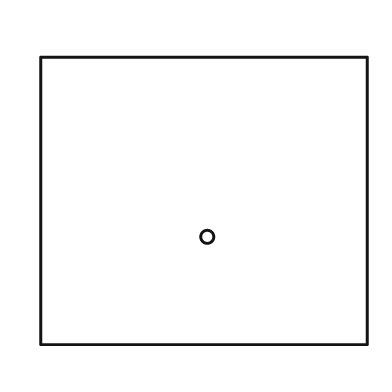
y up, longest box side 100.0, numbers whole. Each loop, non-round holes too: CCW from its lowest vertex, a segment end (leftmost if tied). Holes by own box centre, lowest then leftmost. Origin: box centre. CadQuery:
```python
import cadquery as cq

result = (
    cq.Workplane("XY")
    .moveTo(-50.0, -44.0)
    .lineTo(50.0, -44.0)
    .lineTo(50.0, 44.0)
    .lineTo(-50.0, 44.0)
    .close()
    .moveTo(1.0, -11.0)
    .circle(2.0)
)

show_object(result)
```